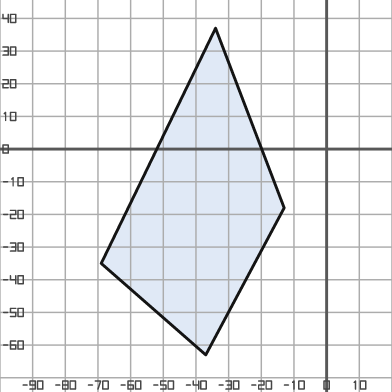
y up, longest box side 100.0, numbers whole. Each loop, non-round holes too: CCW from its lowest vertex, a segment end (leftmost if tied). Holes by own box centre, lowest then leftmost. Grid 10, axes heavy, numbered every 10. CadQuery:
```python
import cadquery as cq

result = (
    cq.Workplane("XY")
    .moveTo(-37.0, -63.0)
    .lineTo(-13.0, -18.0)
    .lineTo(-34.0, 37.0)
    .lineTo(-69.0, -35.0)
    .close()
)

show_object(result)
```